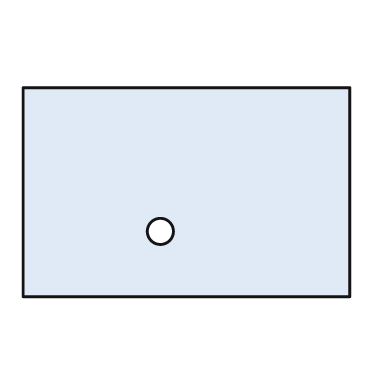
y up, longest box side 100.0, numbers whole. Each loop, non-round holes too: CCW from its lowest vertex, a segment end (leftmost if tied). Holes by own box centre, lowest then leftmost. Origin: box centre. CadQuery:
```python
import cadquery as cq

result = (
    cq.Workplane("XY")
    .moveTo(-50.0, -32.0)
    .lineTo(50.0, -32.0)
    .lineTo(50.0, 32.0)
    .lineTo(-50.0, 32.0)
    .close()
    .moveTo(-8.0, -12.0)
    .circle(4.0)
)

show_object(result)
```